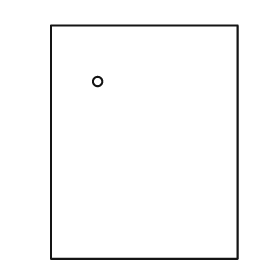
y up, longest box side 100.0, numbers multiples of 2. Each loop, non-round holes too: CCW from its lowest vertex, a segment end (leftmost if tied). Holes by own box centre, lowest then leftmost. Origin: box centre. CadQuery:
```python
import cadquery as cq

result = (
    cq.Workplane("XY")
    .moveTo(-40.0, -50.0)
    .lineTo(40.0, -50.0)
    .lineTo(40.0, 50.0)
    .lineTo(-40.0, 50.0)
    .close()
    .moveTo(-20.0, 26.0)
    .circle(2.0)
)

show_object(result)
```